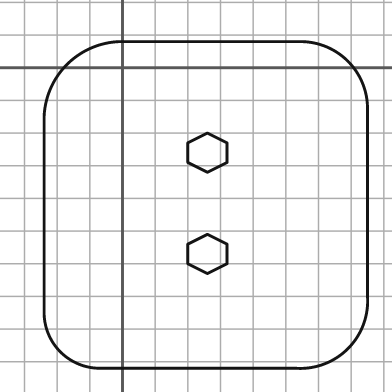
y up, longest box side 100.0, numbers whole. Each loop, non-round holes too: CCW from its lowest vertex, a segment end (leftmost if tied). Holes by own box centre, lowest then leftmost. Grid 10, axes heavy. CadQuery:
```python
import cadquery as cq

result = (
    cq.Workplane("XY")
    .moveTo(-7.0, -92.0)
    .lineTo(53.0, -92.0)
    .threePointArc((69.0, -86.0), (75.0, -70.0))
    .lineTo(75.0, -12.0)
    .threePointArc((69.0, 2.0), (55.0, 8.0))
    .lineTo(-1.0, 8.0)
    .threePointArc((-17.0, 1.0), (-24.0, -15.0))
    .lineTo(-24.0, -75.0)
    .threePointArc((-19.0, -87.0), (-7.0, -92.0))
    .close()
    .moveTo(26.0, -63.0)
    .lineTo(32.0, -60.0)
    .lineTo(32.0, -54.0)
    .lineTo(26.0, -51.0)
    .lineTo(20.0, -54.0)
    .lineTo(20.0, -60.0)
    .close()
    .moveTo(26.0, -32.0)
    .lineTo(32.0, -29.0)
    .lineTo(32.0, -23.0)
    .lineTo(26.0, -20.0)
    .lineTo(20.0, -23.0)
    .lineTo(20.0, -29.0)
    .close()
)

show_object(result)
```